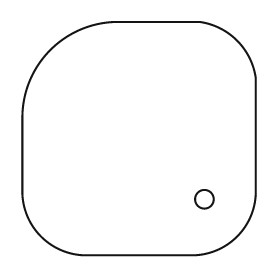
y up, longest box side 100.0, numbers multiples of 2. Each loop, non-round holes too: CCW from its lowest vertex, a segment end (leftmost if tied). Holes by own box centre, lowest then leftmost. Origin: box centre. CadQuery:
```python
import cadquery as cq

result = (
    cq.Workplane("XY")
    .moveTo(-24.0, -50.0)
    .lineTo(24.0, -50.0)
    .threePointArc((42.0, -42.0), (50.0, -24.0))
    .lineTo(50.0, 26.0)
    .threePointArc((42.0, 42.0), (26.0, 50.0))
    .lineTo(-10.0, 50.0)
    .threePointArc((-38.0, 38.0), (-50.0, 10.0))
    .lineTo(-50.0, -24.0)
    .threePointArc((-42.0, -42.0), (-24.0, -50.0))
    .close()
    .moveTo(28.0, -26.0)
    .circle(4.0)
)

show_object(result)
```